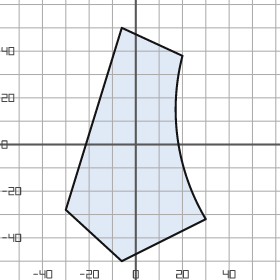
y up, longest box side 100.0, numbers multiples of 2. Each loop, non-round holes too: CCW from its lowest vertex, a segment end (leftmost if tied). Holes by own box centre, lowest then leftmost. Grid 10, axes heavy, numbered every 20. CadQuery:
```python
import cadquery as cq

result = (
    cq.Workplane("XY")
    .moveTo(-6.0, -50.0)
    .lineTo(30.0, -32.0)
    .threePointArc((18.0, 2.0), (20.0, 38.0))
    .lineTo(-6.0, 50.0)
    .lineTo(-30.0, -28.0)
    .close()
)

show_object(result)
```